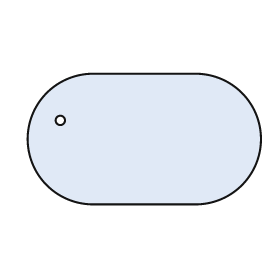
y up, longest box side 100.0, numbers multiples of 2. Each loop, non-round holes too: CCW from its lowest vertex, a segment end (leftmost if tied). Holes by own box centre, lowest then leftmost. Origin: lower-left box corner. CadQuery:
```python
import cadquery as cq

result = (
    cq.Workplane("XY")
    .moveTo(28.0, 0.0)
    .lineTo(72.0, 0.0)
    .threePointArc((100.0, 28.0), (72.0, 56.0))
    .lineTo(28.0, 56.0)
    .threePointArc((0.0, 28.0), (28.0, 0.0))
    .close()
    .moveTo(14.0, 36.0)
    .circle(2.0)
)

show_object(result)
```